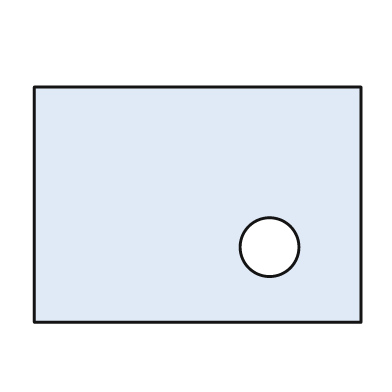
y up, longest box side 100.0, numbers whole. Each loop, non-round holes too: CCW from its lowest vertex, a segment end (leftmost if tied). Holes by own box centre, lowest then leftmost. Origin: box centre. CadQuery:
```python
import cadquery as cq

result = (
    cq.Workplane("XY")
    .moveTo(-50.0, -36.0)
    .lineTo(50.0, -36.0)
    .lineTo(50.0, 36.0)
    .lineTo(-50.0, 36.0)
    .close()
    .moveTo(22.0, -13.0)
    .circle(9.0)
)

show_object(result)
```